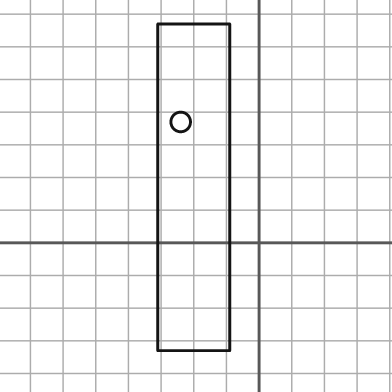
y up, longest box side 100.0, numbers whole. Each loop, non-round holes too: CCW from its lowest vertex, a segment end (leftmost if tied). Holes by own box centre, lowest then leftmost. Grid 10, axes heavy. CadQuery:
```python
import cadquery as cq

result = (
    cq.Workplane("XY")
    .moveTo(-31.0, -33.0)
    .lineTo(-9.0, -33.0)
    .lineTo(-9.0, 67.0)
    .lineTo(-31.0, 67.0)
    .close()
    .moveTo(-24.0, 37.0)
    .circle(3.0)
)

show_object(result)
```